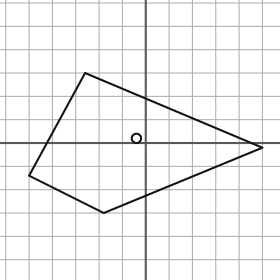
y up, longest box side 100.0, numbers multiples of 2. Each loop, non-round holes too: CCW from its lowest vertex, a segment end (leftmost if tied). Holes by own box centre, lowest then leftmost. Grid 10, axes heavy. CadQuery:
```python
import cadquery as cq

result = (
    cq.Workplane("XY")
    .moveTo(-18.0, -30.0)
    .lineTo(50.0, -2.0)
    .lineTo(-26.0, 30.0)
    .lineTo(-50.0, -14.0)
    .close()
    .moveTo(-4.0, 2.0)
    .circle(2.0)
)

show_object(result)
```